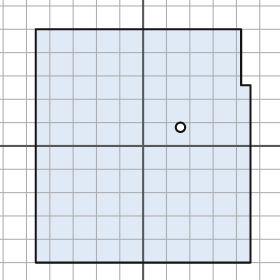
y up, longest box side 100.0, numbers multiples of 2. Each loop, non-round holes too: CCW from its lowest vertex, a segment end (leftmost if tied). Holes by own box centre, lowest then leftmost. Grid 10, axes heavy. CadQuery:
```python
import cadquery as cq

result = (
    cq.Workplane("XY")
    .moveTo(-46.0, -50.0)
    .lineTo(46.0, -50.0)
    .lineTo(46.0, 26.0)
    .lineTo(42.0, 26.0)
    .lineTo(42.0, 50.0)
    .lineTo(-46.0, 50.0)
    .close()
    .moveTo(16.0, 8.0)
    .circle(2.0)
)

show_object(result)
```